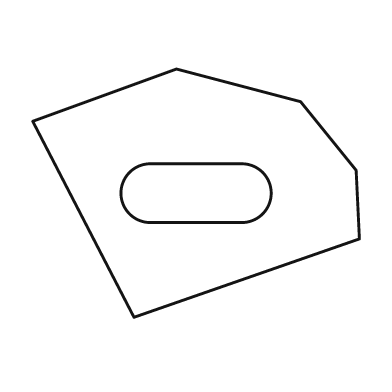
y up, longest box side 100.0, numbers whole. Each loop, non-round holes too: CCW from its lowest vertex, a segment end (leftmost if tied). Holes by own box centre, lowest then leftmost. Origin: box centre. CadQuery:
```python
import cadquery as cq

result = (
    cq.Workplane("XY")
    .moveTo(-19.0, -38.0)
    .lineTo(50.0, -14.0)
    .lineTo(49.0, 7.0)
    .lineTo(32.0, 28.0)
    .lineTo(-6.0, 38.0)
    .lineTo(-50.0, 22.0)
    .close()
    .moveTo(-14.0, -9.0)
    .lineTo(14.0, -9.0)
    .threePointArc((23.0, 0.0), (14.0, 9.0))
    .lineTo(-14.0, 9.0)
    .threePointArc((-23.0, 0.0), (-14.0, -9.0))
    .close()
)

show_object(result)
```